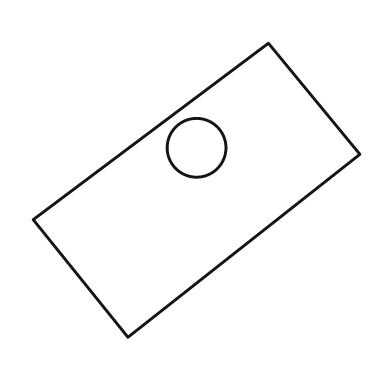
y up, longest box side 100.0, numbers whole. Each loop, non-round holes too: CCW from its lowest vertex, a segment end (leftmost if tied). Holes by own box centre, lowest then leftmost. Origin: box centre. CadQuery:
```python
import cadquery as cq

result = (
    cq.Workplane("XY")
    .moveTo(-21.0, -45.0)
    .lineTo(50.0, 11.0)
    .lineTo(22.0, 45.0)
    .lineTo(-50.0, -9.0)
    .close()
    .moveTo(0.0, 13.0)
    .circle(9.0)
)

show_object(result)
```